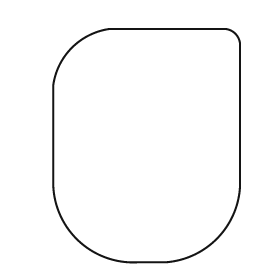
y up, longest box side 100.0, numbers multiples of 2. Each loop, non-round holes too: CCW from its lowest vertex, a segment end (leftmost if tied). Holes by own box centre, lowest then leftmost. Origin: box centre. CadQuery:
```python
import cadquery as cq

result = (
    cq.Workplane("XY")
    .moveTo(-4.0, -50.0)
    .lineTo(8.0, -50.0)
    .threePointArc((30.0, -40.0), (40.0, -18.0))
    .lineTo(40.0, 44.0)
    .threePointArc((38.0, 48.0), (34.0, 50.0))
    .lineTo(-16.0, 50.0)
    .threePointArc((-32.0, 42.0), (-40.0, 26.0))
    .lineTo(-40.0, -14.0)
    .threePointArc((-30.0, -40.0), (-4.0, -50.0))
    .close()
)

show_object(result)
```